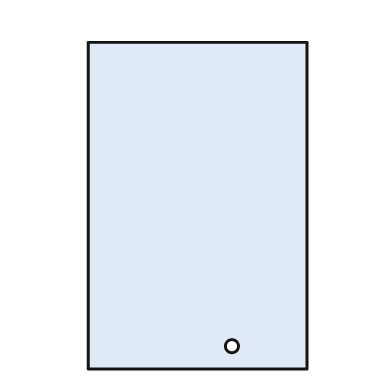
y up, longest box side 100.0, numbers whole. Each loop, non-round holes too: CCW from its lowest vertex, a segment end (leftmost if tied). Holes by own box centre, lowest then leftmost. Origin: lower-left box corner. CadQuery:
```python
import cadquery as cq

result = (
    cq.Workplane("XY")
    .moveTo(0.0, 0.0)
    .lineTo(67.0, 0.0)
    .lineTo(67.0, 100.0)
    .lineTo(0.0, 100.0)
    .close()
    .moveTo(44.0, 7.0)
    .circle(2.0)
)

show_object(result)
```